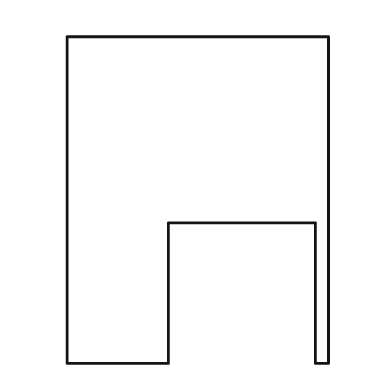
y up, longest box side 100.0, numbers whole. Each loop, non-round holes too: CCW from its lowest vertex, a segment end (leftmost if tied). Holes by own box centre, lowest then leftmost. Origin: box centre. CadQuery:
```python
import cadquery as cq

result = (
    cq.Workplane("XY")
    .moveTo(-40.0, -50.0)
    .lineTo(-9.0, -50.0)
    .lineTo(-9.0, -7.0)
    .lineTo(36.0, -7.0)
    .lineTo(36.0, -50.0)
    .lineTo(40.0, -50.0)
    .lineTo(40.0, 50.0)
    .lineTo(-40.0, 50.0)
    .close()
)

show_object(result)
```